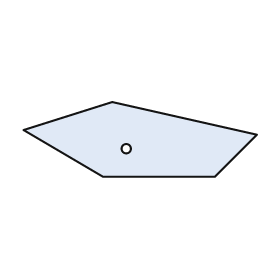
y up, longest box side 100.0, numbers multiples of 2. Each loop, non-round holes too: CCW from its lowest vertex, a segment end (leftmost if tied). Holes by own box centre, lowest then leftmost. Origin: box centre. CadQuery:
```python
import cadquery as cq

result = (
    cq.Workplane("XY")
    .moveTo(-16.0, -16.0)
    .lineTo(32.0, -16.0)
    .lineTo(50.0, 2.0)
    .lineTo(-12.0, 16.0)
    .lineTo(-50.0, 4.0)
    .close()
    .moveTo(-6.0, -4.0)
    .circle(2.0)
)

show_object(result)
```